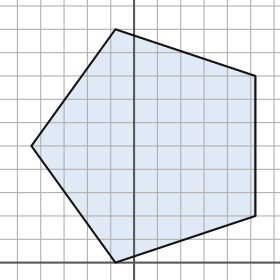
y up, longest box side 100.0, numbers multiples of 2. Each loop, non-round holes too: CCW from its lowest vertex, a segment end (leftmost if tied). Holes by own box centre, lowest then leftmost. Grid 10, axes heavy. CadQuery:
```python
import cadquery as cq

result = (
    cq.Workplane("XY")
    .moveTo(-8.0, 0.0)
    .lineTo(52.0, 20.0)
    .lineTo(52.0, 80.0)
    .lineTo(-8.0, 100.0)
    .lineTo(-44.0, 50.0)
    .close()
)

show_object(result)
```